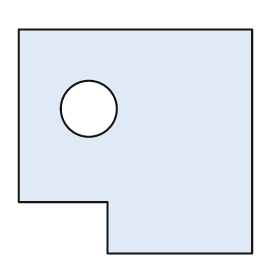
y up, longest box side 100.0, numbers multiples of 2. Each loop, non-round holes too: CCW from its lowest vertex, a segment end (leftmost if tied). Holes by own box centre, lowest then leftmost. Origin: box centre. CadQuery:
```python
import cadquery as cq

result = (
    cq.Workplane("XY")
    .moveTo(-12.0, -48.0)
    .lineTo(50.0, -48.0)
    .lineTo(50.0, 48.0)
    .lineTo(-50.0, 48.0)
    .lineTo(-50.0, -26.0)
    .lineTo(-12.0, -26.0)
    .close()
    .moveTo(-20.0, 14.0)
    .circle(12.0)
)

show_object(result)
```